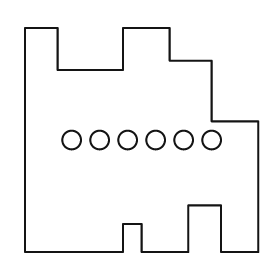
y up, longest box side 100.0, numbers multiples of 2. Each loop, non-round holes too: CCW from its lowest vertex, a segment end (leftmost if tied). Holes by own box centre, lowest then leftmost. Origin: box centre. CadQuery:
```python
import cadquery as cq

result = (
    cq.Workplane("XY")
    .moveTo(-50.0, -48.0)
    .lineTo(-8.0, -48.0)
    .lineTo(-8.0, -36.0)
    .lineTo(0.0, -36.0)
    .lineTo(0.0, -48.0)
    .lineTo(20.0, -48.0)
    .lineTo(20.0, -28.0)
    .lineTo(34.0, -28.0)
    .lineTo(34.0, -48.0)
    .lineTo(50.0, -48.0)
    .lineTo(50.0, 8.0)
    .lineTo(30.0, 8.0)
    .lineTo(30.0, 34.0)
    .lineTo(12.0, 34.0)
    .lineTo(12.0, 48.0)
    .lineTo(-8.0, 48.0)
    .lineTo(-8.0, 30.0)
    .lineTo(-36.0, 30.0)
    .lineTo(-36.0, 48.0)
    .lineTo(-50.0, 48.0)
    .close()
    .moveTo(-30.0, 0.0)
    .circle(4.0)
    .moveTo(-18.0, 0.0)
    .circle(4.0)
    .moveTo(-6.0, 0.0)
    .circle(4.0)
    .moveTo(6.0, 0.0)
    .circle(4.0)
    .moveTo(18.0, 0.0)
    .circle(4.0)
    .moveTo(30.0, 0.0)
    .circle(4.0)
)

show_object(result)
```